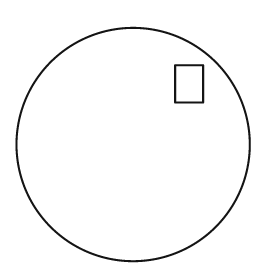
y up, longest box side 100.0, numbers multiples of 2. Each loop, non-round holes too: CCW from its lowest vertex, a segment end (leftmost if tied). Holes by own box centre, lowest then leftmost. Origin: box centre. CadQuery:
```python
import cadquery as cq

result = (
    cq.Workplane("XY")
    .moveTo(0.0, 0.0)
    .circle(50.0)
    .moveTo(18.0, 18.0)
    .lineTo(30.0, 18.0)
    .lineTo(30.0, 34.0)
    .lineTo(18.0, 34.0)
    .close()
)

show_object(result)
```